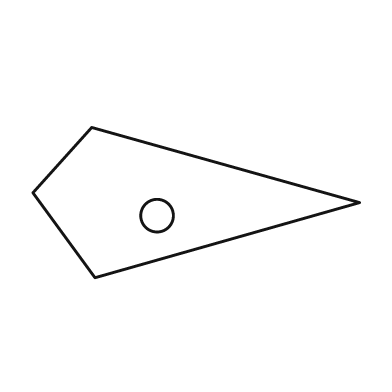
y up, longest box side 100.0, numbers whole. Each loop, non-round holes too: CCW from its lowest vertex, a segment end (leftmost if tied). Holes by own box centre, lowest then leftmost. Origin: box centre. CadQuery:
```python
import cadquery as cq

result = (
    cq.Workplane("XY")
    .moveTo(-31.0, -23.0)
    .lineTo(50.0, 0.0)
    .lineTo(-32.0, 23.0)
    .lineTo(-50.0, 3.0)
    .close()
    .moveTo(-12.0, -4.0)
    .circle(5.0)
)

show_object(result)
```